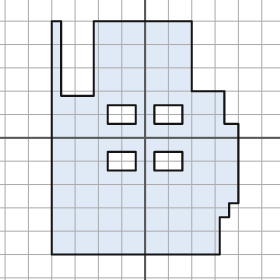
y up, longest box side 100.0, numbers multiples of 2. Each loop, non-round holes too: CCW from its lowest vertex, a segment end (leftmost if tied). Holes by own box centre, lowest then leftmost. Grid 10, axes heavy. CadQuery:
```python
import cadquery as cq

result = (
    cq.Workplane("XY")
    .moveTo(-40.0, -50.0)
    .lineTo(32.0, -50.0)
    .lineTo(32.0, -34.0)
    .lineTo(36.0, -34.0)
    .lineTo(36.0, -28.0)
    .lineTo(40.0, -28.0)
    .lineTo(40.0, 6.0)
    .lineTo(34.0, 6.0)
    .lineTo(34.0, 20.0)
    .lineTo(20.0, 20.0)
    .lineTo(20.0, 50.0)
    .lineTo(-22.0, 50.0)
    .lineTo(-22.0, 18.0)
    .lineTo(-36.0, 18.0)
    .lineTo(-36.0, 50.0)
    .lineTo(-40.0, 50.0)
    .close()
    .moveTo(-16.0, -14.0)
    .lineTo(-4.0, -14.0)
    .lineTo(-4.0, -6.0)
    .lineTo(-16.0, -6.0)
    .close()
    .moveTo(4.0, -14.0)
    .lineTo(16.0, -14.0)
    .lineTo(16.0, -6.0)
    .lineTo(4.0, -6.0)
    .close()
    .moveTo(-16.0, 6.0)
    .lineTo(-4.0, 6.0)
    .lineTo(-4.0, 14.0)
    .lineTo(-16.0, 14.0)
    .close()
    .moveTo(4.0, 6.0)
    .lineTo(16.0, 6.0)
    .lineTo(16.0, 14.0)
    .lineTo(4.0, 14.0)
    .close()
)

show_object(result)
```